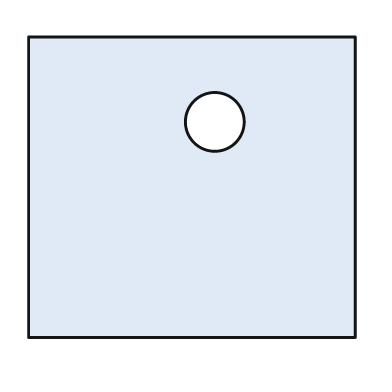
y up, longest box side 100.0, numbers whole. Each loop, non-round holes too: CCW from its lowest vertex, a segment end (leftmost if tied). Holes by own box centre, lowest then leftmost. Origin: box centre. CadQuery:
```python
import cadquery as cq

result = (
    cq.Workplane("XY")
    .moveTo(-50.0, -46.0)
    .lineTo(50.0, -46.0)
    .lineTo(50.0, 46.0)
    .lineTo(-50.0, 46.0)
    .close()
    .moveTo(7.0, 20.0)
    .circle(9.0)
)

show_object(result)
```